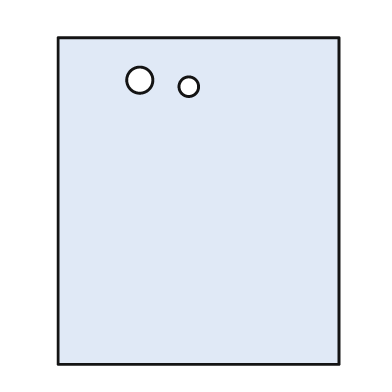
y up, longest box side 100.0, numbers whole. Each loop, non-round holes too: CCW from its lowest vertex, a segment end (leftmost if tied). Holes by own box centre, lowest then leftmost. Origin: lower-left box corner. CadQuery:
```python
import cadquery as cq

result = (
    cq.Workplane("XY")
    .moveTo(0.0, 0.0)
    .lineTo(86.0, 0.0)
    .lineTo(86.0, 100.0)
    .lineTo(0.0, 100.0)
    .close()
    .moveTo(40.0, 85.0)
    .circle(3.0)
    .moveTo(25.0, 87.0)
    .circle(4.0)
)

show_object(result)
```